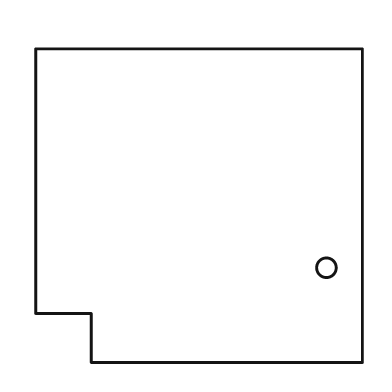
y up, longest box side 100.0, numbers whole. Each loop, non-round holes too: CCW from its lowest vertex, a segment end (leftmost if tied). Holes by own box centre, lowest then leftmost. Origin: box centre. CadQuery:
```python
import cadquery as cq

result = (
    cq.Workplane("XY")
    .moveTo(-33.0, -48.0)
    .lineTo(50.0, -48.0)
    .lineTo(50.0, 48.0)
    .lineTo(-50.0, 48.0)
    .lineTo(-50.0, -33.0)
    .lineTo(-33.0, -33.0)
    .close()
    .moveTo(39.0, -19.0)
    .circle(3.0)
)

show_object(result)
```